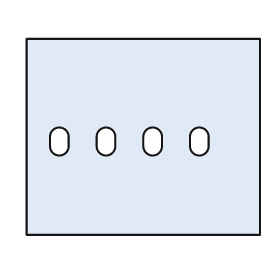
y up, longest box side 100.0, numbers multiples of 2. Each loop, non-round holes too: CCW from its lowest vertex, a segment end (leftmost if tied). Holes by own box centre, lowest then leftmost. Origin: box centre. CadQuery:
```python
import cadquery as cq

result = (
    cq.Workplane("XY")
    .moveTo(-50.0, -42.0)
    .lineTo(50.0, -42.0)
    .lineTo(50.0, 42.0)
    .lineTo(-50.0, 42.0)
    .close()
    .moveTo(-40.0, -4.0)
    .threePointArc((-36.0, -8.0), (-32.0, -4.0))
    .lineTo(-32.0, 0.0)
    .threePointArc((-36.0, 4.0), (-40.0, 0.0))
    .close()
    .moveTo(-20.0, -4.0)
    .threePointArc((-16.0, -8.0), (-12.0, -4.0))
    .lineTo(-12.0, 0.0)
    .threePointArc((-16.0, 4.0), (-20.0, 0.0))
    .close()
    .moveTo(0.0, -4.0)
    .threePointArc((4.0, -8.0), (8.0, -4.0))
    .lineTo(8.0, 0.0)
    .threePointArc((4.0, 4.0), (0.0, 0.0))
    .close()
    .moveTo(20.0, -4.0)
    .threePointArc((24.0, -8.0), (28.0, -4.0))
    .lineTo(28.0, 0.0)
    .threePointArc((24.0, 4.0), (20.0, 0.0))
    .close()
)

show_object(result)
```